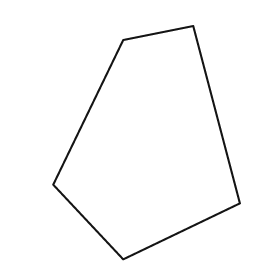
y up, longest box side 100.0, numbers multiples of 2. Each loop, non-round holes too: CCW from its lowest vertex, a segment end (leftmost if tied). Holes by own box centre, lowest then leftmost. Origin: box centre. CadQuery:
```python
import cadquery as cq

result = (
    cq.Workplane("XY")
    .moveTo(-10.0, -50.0)
    .lineTo(40.0, -26.0)
    .lineTo(20.0, 50.0)
    .lineTo(-10.0, 44.0)
    .lineTo(-40.0, -18.0)
    .close()
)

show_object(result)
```